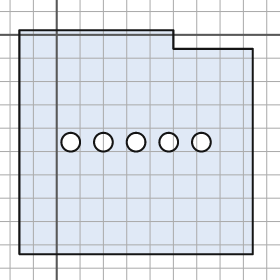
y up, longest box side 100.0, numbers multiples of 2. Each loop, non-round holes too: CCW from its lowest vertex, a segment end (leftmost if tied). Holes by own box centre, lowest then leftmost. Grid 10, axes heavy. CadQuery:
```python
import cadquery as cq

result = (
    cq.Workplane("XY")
    .moveTo(-16.0, -94.0)
    .lineTo(84.0, -94.0)
    .lineTo(84.0, -6.0)
    .lineTo(50.0, -6.0)
    .lineTo(50.0, 2.0)
    .lineTo(-16.0, 2.0)
    .close()
    .moveTo(6.0, -46.0)
    .circle(4.0)
    .moveTo(20.0, -46.0)
    .circle(4.0)
    .moveTo(34.0, -46.0)
    .circle(4.0)
    .moveTo(48.0, -46.0)
    .circle(4.0)
    .moveTo(62.0, -46.0)
    .circle(4.0)
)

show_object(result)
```